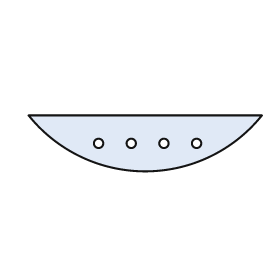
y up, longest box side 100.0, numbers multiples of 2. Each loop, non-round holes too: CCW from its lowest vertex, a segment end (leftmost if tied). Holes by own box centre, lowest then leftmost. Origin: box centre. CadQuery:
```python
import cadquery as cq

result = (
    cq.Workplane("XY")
    .moveTo(-50.0, 12.0)
    .threePointArc((0.0, -12.0), (50.0, 12.0))
    .close()
    .moveTo(-20.0, 0.0)
    .circle(2.0)
    .moveTo(-6.0, 0.0)
    .circle(2.0)
    .moveTo(8.0, 0.0)
    .circle(2.0)
    .moveTo(22.0, 0.0)
    .circle(2.0)
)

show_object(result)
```